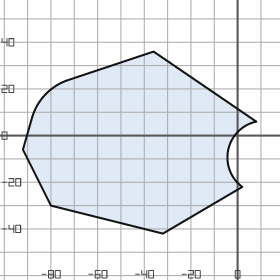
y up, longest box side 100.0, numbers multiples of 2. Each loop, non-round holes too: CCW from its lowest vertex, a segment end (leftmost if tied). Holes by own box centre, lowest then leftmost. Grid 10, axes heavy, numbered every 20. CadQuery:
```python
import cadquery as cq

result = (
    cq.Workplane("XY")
    .moveTo(-32.0, -42.0)
    .lineTo(2.0, -22.0)
    .threePointArc((-4.0, -6.0), (8.0, 6.0))
    .lineTo(-36.0, 36.0)
    .lineTo(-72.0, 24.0)
    .threePointArc((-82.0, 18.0), (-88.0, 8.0))
    .lineTo(-92.0, -6.0)
    .lineTo(-80.0, -30.0)
    .close()
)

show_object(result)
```